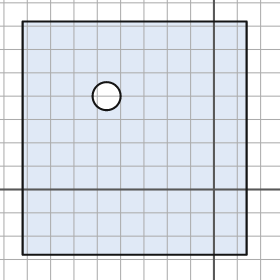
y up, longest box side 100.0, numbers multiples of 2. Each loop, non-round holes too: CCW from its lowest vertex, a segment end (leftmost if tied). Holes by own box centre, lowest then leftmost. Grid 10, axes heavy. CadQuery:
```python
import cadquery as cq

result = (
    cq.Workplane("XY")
    .moveTo(-82.0, -28.0)
    .lineTo(14.0, -28.0)
    .lineTo(14.0, 72.0)
    .lineTo(-82.0, 72.0)
    .close()
    .moveTo(-46.0, 40.0)
    .circle(6.0)
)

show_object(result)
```